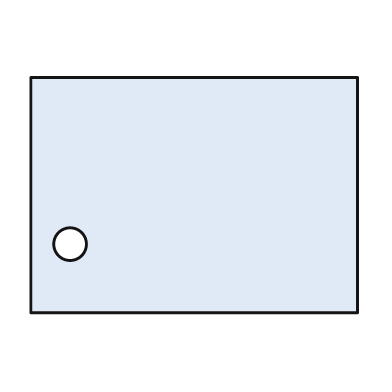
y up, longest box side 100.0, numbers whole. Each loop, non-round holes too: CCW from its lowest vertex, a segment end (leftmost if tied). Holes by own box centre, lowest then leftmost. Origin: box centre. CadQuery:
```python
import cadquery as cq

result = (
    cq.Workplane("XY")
    .moveTo(-50.0, -36.0)
    .lineTo(50.0, -36.0)
    .lineTo(50.0, 36.0)
    .lineTo(-50.0, 36.0)
    .close()
    .moveTo(-38.0, -15.0)
    .circle(5.0)
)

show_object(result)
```